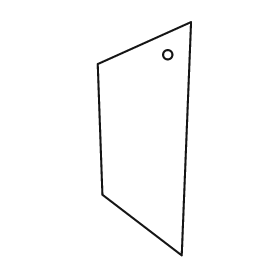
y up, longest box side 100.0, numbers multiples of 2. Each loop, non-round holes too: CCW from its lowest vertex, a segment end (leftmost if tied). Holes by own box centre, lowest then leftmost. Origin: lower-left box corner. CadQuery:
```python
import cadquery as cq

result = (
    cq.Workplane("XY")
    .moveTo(36.0, 0.0)
    .lineTo(40.0, 100.0)
    .lineTo(0.0, 82.0)
    .lineTo(2.0, 26.0)
    .close()
    .moveTo(30.0, 86.0)
    .circle(2.0)
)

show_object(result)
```